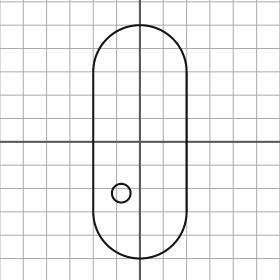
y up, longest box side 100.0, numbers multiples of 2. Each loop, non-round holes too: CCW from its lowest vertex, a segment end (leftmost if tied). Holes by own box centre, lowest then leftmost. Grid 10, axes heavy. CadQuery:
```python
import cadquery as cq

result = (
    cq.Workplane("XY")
    .moveTo(-20.0, -30.0)
    .threePointArc((0.0, -50.0), (20.0, -30.0))
    .lineTo(20.0, 30.0)
    .threePointArc((0.0, 50.0), (-20.0, 30.0))
    .close()
    .moveTo(-8.0, -22.0)
    .circle(4.0)
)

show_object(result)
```